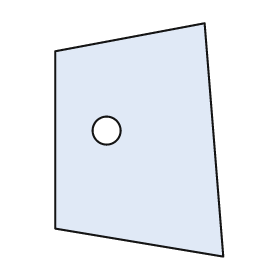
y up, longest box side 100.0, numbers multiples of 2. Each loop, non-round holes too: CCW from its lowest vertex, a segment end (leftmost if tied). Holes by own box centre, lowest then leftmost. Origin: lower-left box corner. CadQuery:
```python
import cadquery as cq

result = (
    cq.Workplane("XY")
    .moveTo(72.0, 0.0)
    .lineTo(64.0, 100.0)
    .lineTo(0.0, 88.0)
    .lineTo(0.0, 12.0)
    .close()
    .moveTo(22.0, 54.0)
    .circle(6.0)
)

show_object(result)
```